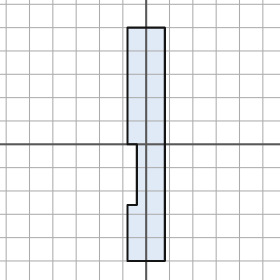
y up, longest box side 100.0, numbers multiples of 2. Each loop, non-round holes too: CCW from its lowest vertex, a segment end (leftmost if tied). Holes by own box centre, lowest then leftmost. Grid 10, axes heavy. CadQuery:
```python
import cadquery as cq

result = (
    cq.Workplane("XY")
    .moveTo(-8.0, -50.0)
    .lineTo(8.0, -50.0)
    .lineTo(8.0, 50.0)
    .lineTo(-8.0, 50.0)
    .lineTo(-8.0, 0.0)
    .lineTo(-4.0, 0.0)
    .lineTo(-4.0, -26.0)
    .lineTo(-8.0, -26.0)
    .close()
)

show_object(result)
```